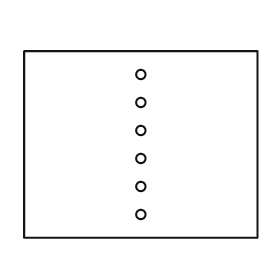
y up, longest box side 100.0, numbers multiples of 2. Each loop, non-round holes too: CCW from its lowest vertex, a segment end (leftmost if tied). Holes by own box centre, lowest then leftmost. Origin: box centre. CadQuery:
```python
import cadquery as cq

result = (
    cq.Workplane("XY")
    .moveTo(-50.0, -40.0)
    .lineTo(50.0, -40.0)
    .lineTo(50.0, 40.0)
    .lineTo(-50.0, 40.0)
    .close()
    .moveTo(0.0, -30.0)
    .circle(2.0)
    .moveTo(0.0, -18.0)
    .circle(2.0)
    .moveTo(0.0, -6.0)
    .circle(2.0)
    .moveTo(0.0, 6.0)
    .circle(2.0)
    .moveTo(0.0, 18.0)
    .circle(2.0)
    .moveTo(0.0, 30.0)
    .circle(2.0)
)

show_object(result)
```